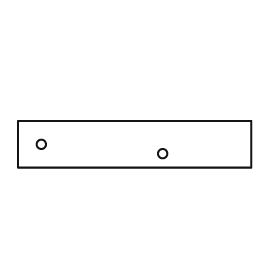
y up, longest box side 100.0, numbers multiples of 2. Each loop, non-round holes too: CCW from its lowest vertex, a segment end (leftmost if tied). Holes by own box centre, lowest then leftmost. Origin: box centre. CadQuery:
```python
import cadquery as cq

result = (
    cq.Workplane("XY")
    .moveTo(-50.0, -10.0)
    .lineTo(50.0, -10.0)
    .lineTo(50.0, 10.0)
    .lineTo(-50.0, 10.0)
    .close()
    .moveTo(12.0, -4.0)
    .circle(2.0)
    .moveTo(-40.0, 0.0)
    .circle(2.0)
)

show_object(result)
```